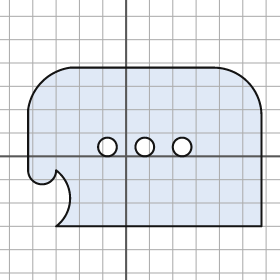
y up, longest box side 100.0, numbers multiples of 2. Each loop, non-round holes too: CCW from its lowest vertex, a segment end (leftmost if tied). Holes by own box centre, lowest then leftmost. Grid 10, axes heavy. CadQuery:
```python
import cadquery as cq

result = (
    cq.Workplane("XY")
    .moveTo(-30.0, -30.0)
    .lineTo(58.0, -30.0)
    .lineTo(58.0, 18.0)
    .threePointArc((52.0, 32.0), (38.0, 38.0))
    .lineTo(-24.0, 38.0)
    .threePointArc((-36.0, 32.0), (-42.0, 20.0))
    .lineTo(-42.0, -6.0)
    .threePointArc((-36.0, -12.0), (-30.0, -6.0))
    .threePointArc((-24.0, -18.0), (-30.0, -30.0))
    .close()
    .moveTo(-8.0, 4.0)
    .circle(4.0)
    .moveTo(8.0, 4.0)
    .circle(4.0)
    .moveTo(24.0, 4.0)
    .circle(4.0)
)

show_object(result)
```